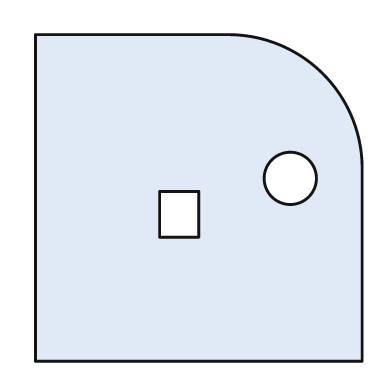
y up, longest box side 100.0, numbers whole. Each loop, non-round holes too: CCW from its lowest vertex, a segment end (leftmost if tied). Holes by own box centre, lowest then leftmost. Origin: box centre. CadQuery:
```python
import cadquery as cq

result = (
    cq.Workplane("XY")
    .moveTo(-50.0, -50.0)
    .lineTo(50.0, -50.0)
    .lineTo(50.0, 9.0)
    .threePointArc((38.0, 38.0), (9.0, 50.0))
    .lineTo(-50.0, 50.0)
    .close()
    .moveTo(-12.0, -12.0)
    .lineTo(0.0, -12.0)
    .lineTo(0.0, 2.0)
    .lineTo(-12.0, 2.0)
    .close()
    .moveTo(28.0, 6.0)
    .circle(8.0)
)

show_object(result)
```